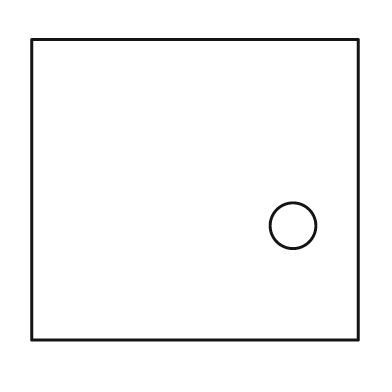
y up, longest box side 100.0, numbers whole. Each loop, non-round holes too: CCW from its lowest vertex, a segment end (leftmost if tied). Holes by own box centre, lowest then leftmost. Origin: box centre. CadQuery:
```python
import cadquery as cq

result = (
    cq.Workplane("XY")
    .moveTo(-50.0, -46.0)
    .lineTo(50.0, -46.0)
    .lineTo(50.0, 46.0)
    .lineTo(-50.0, 46.0)
    .close()
    .moveTo(30.0, -11.0)
    .circle(7.0)
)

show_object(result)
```